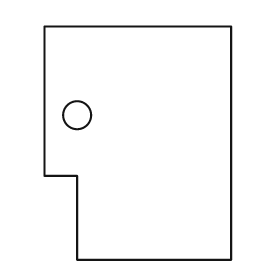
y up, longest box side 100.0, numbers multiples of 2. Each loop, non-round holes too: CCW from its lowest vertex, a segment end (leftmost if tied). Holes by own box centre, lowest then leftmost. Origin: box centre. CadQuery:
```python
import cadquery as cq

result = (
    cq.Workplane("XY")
    .moveTo(-26.0, -50.0)
    .lineTo(40.0, -50.0)
    .lineTo(40.0, 50.0)
    .lineTo(-40.0, 50.0)
    .lineTo(-40.0, -14.0)
    .lineTo(-26.0, -14.0)
    .close()
    .moveTo(-26.0, 12.0)
    .circle(6.0)
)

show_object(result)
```